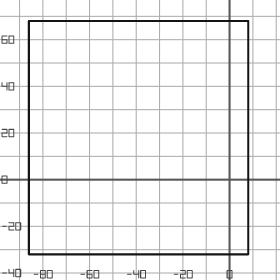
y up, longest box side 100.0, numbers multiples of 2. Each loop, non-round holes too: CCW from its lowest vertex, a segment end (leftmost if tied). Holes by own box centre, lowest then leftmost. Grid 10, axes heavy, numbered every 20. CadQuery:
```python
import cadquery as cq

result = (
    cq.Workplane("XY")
    .moveTo(-86.0, -32.0)
    .lineTo(8.0, -32.0)
    .lineTo(8.0, 68.0)
    .lineTo(-86.0, 68.0)
    .close()
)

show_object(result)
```